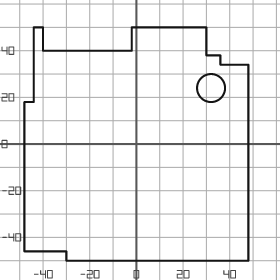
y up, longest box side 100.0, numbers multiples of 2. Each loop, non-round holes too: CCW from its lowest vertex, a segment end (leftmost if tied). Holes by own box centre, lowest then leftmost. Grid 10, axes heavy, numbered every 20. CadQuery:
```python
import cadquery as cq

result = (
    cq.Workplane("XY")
    .moveTo(-30.0, -50.0)
    .lineTo(48.0, -50.0)
    .lineTo(48.0, 34.0)
    .lineTo(36.0, 34.0)
    .lineTo(36.0, 38.0)
    .lineTo(30.0, 38.0)
    .lineTo(30.0, 50.0)
    .lineTo(-2.0, 50.0)
    .lineTo(-2.0, 40.0)
    .lineTo(-40.0, 40.0)
    .lineTo(-40.0, 50.0)
    .lineTo(-44.0, 50.0)
    .lineTo(-44.0, 18.0)
    .lineTo(-48.0, 18.0)
    .lineTo(-48.0, -46.0)
    .lineTo(-30.0, -46.0)
    .close()
    .moveTo(32.0, 24.0)
    .circle(6.0)
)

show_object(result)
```